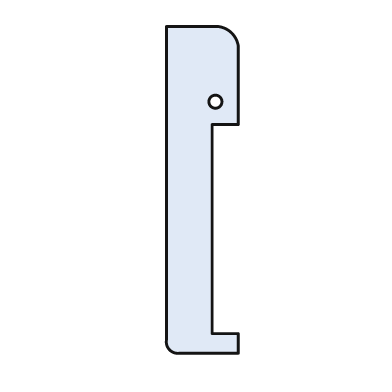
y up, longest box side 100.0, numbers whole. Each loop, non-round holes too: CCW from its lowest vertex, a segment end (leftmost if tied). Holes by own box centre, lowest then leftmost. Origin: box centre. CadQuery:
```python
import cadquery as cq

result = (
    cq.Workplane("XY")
    .moveTo(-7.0, -50.0)
    .lineTo(11.0, -50.0)
    .lineTo(11.0, -44.0)
    .lineTo(3.0, -44.0)
    .lineTo(3.0, 20.0)
    .lineTo(11.0, 20.0)
    .lineTo(11.0, 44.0)
    .threePointArc((9.0, 48.0), (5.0, 50.0))
    .lineTo(-11.0, 50.0)
    .lineTo(-11.0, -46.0)
    .threePointArc((-10.0, -49.0), (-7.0, -50.0))
    .close()
    .moveTo(4.0, 27.0)
    .circle(2.0)
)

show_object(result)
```